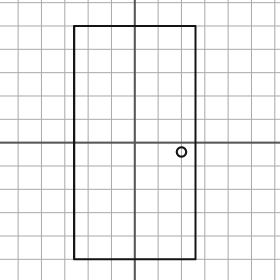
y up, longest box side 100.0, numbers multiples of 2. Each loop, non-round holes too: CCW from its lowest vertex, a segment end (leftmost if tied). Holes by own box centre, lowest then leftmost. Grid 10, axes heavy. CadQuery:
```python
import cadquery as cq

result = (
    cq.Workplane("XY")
    .moveTo(-26.0, -50.0)
    .lineTo(26.0, -50.0)
    .lineTo(26.0, 50.0)
    .lineTo(-26.0, 50.0)
    .close()
    .moveTo(20.0, -4.0)
    .circle(2.0)
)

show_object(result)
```